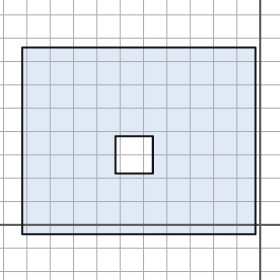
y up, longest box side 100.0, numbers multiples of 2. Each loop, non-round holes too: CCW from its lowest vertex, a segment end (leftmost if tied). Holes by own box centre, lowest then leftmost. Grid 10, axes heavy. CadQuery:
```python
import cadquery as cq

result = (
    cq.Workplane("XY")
    .moveTo(-102.0, -4.0)
    .lineTo(-2.0, -4.0)
    .lineTo(-2.0, 76.0)
    .lineTo(-102.0, 76.0)
    .close()
    .moveTo(-62.0, 22.0)
    .lineTo(-46.0, 22.0)
    .lineTo(-46.0, 38.0)
    .lineTo(-62.0, 38.0)
    .close()
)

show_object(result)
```